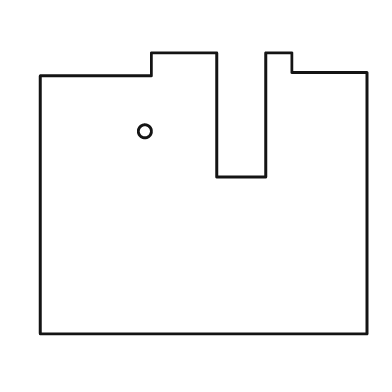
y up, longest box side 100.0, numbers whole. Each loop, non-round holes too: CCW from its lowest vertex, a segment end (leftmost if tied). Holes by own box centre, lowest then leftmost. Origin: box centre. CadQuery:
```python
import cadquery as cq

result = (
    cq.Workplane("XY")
    .moveTo(-50.0, -43.0)
    .lineTo(50.0, -43.0)
    .lineTo(50.0, 37.0)
    .lineTo(27.0, 37.0)
    .lineTo(27.0, 43.0)
    .lineTo(19.0, 43.0)
    .lineTo(19.0, 5.0)
    .lineTo(4.0, 5.0)
    .lineTo(4.0, 43.0)
    .lineTo(-16.0, 43.0)
    .lineTo(-16.0, 36.0)
    .lineTo(-50.0, 36.0)
    .close()
    .moveTo(-18.0, 19.0)
    .circle(2.0)
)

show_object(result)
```